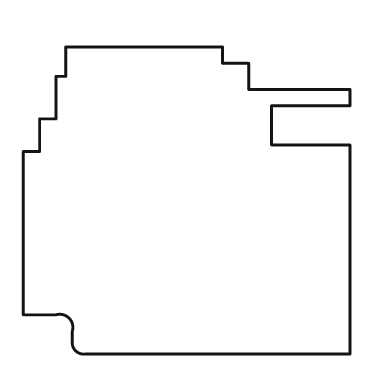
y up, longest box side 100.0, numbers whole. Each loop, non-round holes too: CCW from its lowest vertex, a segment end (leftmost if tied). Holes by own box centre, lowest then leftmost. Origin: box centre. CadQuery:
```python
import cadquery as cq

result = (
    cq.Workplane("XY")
    .moveTo(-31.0, -47.0)
    .lineTo(50.0, -47.0)
    .lineTo(50.0, 17.0)
    .lineTo(26.0, 17.0)
    .lineTo(26.0, 29.0)
    .lineTo(50.0, 29.0)
    .lineTo(50.0, 34.0)
    .lineTo(19.0, 34.0)
    .lineTo(19.0, 42.0)
    .lineTo(11.0, 42.0)
    .lineTo(11.0, 47.0)
    .lineTo(-37.0, 47.0)
    .lineTo(-37.0, 38.0)
    .lineTo(-40.0, 38.0)
    .lineTo(-40.0, 25.0)
    .lineTo(-45.0, 25.0)
    .lineTo(-45.0, 15.0)
    .lineTo(-50.0, 15.0)
    .lineTo(-50.0, -35.0)
    .lineTo(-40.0, -35.0)
    .threePointArc((-36.0, -36.0), (-35.0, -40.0))
    .lineTo(-35.0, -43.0)
    .threePointArc((-34.0, -46.0), (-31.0, -47.0))
    .close()
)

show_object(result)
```